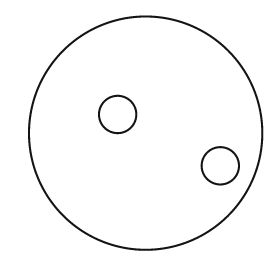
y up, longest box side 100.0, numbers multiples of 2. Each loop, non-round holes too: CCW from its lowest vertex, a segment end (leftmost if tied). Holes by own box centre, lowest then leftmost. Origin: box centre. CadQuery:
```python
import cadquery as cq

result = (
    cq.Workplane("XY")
    .moveTo(0.0, 0.0)
    .circle(50.0)
    .moveTo(32.0, -14.0)
    .circle(8.0)
    .moveTo(-12.0, 8.0)
    .circle(8.0)
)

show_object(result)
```